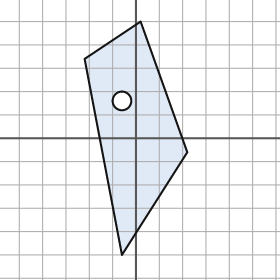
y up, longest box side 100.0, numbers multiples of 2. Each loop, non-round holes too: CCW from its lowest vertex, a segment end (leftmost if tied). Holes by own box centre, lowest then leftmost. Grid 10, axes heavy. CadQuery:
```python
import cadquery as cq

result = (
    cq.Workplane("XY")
    .moveTo(-6.0, -50.0)
    .lineTo(22.0, -6.0)
    .lineTo(2.0, 50.0)
    .lineTo(-22.0, 34.0)
    .close()
    .moveTo(-6.0, 16.0)
    .circle(4.0)
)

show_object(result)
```